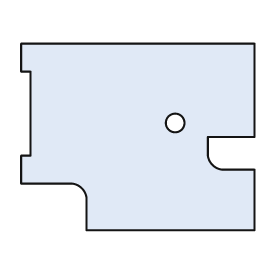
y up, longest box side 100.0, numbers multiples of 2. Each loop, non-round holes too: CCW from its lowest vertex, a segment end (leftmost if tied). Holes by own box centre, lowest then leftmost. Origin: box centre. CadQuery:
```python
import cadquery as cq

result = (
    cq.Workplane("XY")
    .moveTo(-22.0, -40.0)
    .lineTo(50.0, -40.0)
    .lineTo(50.0, -14.0)
    .lineTo(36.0, -14.0)
    .threePointArc((32.0, -12.0), (30.0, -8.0))
    .lineTo(30.0, 0.0)
    .lineTo(50.0, 0.0)
    .lineTo(50.0, 40.0)
    .lineTo(-50.0, 40.0)
    .lineTo(-50.0, 28.0)
    .lineTo(-46.0, 28.0)
    .lineTo(-46.0, -8.0)
    .lineTo(-50.0, -8.0)
    .lineTo(-50.0, -20.0)
    .lineTo(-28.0, -20.0)
    .threePointArc((-24.0, -22.0), (-22.0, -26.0))
    .close()
    .moveTo(16.0, 6.0)
    .circle(4.0)
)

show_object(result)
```